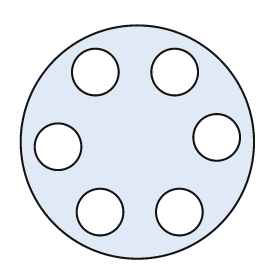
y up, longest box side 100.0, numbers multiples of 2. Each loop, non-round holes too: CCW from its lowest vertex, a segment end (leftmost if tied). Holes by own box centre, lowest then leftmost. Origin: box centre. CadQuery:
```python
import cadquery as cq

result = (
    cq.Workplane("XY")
    .moveTo(0.0, 0.0)
    .circle(50.0)
    .moveTo(-16.0, -30.0)
    .circle(10.0)
    .moveTo(18.0, -30.0)
    .circle(10.0)
    .moveTo(-34.0, -2.0)
    .circle(10.0)
    .moveTo(34.0, 2.0)
    .circle(10.0)
    .moveTo(-18.0, 30.0)
    .circle(10.0)
    .moveTo(16.0, 30.0)
    .circle(10.0)
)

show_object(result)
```